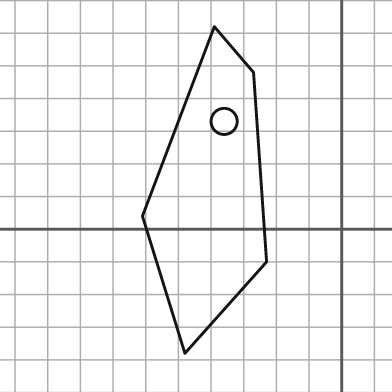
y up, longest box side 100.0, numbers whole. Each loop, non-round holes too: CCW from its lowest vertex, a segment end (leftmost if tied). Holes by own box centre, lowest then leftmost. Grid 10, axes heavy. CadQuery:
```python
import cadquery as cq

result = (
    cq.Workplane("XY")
    .moveTo(-48.0, -38.0)
    .lineTo(-23.0, -10.0)
    .lineTo(-27.0, 48.0)
    .lineTo(-39.0, 62.0)
    .lineTo(-61.0, 4.0)
    .close()
    .moveTo(-36.0, 33.0)
    .circle(4.0)
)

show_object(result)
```